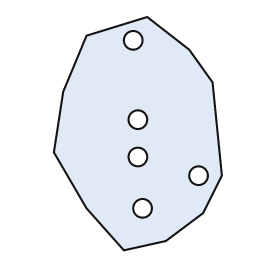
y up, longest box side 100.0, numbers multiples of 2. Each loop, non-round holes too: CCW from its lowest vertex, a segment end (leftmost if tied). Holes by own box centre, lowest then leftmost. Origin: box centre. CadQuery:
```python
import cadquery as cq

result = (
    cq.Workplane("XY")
    .moveTo(-6.0, -50.0)
    .lineTo(12.0, -46.0)
    .lineTo(28.0, -34.0)
    .lineTo(36.0, -18.0)
    .lineTo(32.0, 22.0)
    .lineTo(22.0, 36.0)
    .lineTo(4.0, 50.0)
    .lineTo(-22.0, 42.0)
    .lineTo(-32.0, 18.0)
    .lineTo(-36.0, -8.0)
    .lineTo(-22.0, -32.0)
    .close()
    .moveTo(2.0, -32.0)
    .circle(4.0)
    .moveTo(26.0, -18.0)
    .circle(4.0)
    .moveTo(0.0, -10.0)
    .circle(4.0)
    .moveTo(0.0, 6.0)
    .circle(4.0)
    .moveTo(-2.0, 40.0)
    .circle(4.0)
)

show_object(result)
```